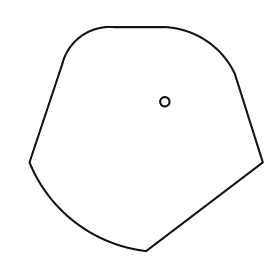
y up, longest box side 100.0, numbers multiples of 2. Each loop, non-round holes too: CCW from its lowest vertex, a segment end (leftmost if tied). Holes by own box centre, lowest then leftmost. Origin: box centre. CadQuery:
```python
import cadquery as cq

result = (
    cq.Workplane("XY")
    .moveTo(0.0, -48.0)
    .lineTo(50.0, -10.0)
    .lineTo(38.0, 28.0)
    .threePointArc((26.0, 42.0), (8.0, 48.0))
    .lineTo(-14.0, 48.0)
    .threePointArc((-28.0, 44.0), (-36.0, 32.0))
    .lineTo(-50.0, -10.0)
    .threePointArc((-30.0, -36.0), (0.0, -48.0))
    .close()
    .moveTo(8.0, 16.0)
    .circle(2.0)
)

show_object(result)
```